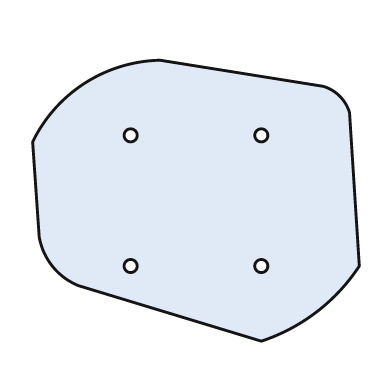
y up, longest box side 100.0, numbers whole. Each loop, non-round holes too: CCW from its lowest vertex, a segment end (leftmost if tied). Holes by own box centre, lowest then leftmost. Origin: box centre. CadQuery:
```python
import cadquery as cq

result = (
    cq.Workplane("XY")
    .moveTo(20.0, -43.0)
    .threePointArc((37.0, -34.0), (50.0, -20.0))
    .lineTo(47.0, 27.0)
    .threePointArc((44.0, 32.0), (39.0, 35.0))
    .lineTo(-11.0, 43.0)
    .threePointArc((-34.0, 36.0), (-50.0, 18.0))
    .lineTo(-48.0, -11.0)
    .threePointArc((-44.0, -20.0), (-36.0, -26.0))
    .close()
    .moveTo(-20.0, -20.0)
    .circle(2.0)
    .moveTo(20.0, -20.0)
    .circle(2.0)
    .moveTo(-20.0, 20.0)
    .circle(2.0)
    .moveTo(20.0, 20.0)
    .circle(2.0)
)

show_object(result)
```